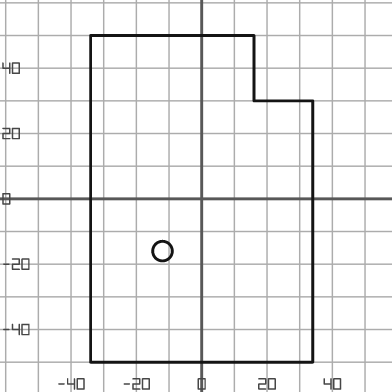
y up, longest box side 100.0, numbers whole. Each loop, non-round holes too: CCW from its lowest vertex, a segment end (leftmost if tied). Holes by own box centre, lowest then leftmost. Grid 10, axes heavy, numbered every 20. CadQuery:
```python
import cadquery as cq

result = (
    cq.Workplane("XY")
    .moveTo(-34.0, -50.0)
    .lineTo(34.0, -50.0)
    .lineTo(34.0, 30.0)
    .lineTo(16.0, 30.0)
    .lineTo(16.0, 50.0)
    .lineTo(-34.0, 50.0)
    .close()
    .moveTo(-12.0, -16.0)
    .circle(3.0)
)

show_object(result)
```